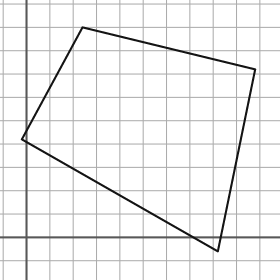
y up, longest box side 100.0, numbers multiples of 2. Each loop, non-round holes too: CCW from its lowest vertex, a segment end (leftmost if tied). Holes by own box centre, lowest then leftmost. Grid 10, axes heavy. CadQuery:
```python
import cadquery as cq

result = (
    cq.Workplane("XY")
    .moveTo(82.0, -6.0)
    .lineTo(98.0, 72.0)
    .lineTo(24.0, 90.0)
    .lineTo(-2.0, 42.0)
    .close()
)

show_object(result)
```